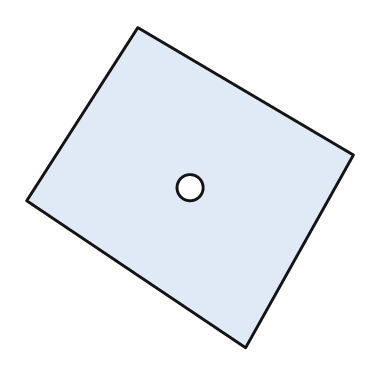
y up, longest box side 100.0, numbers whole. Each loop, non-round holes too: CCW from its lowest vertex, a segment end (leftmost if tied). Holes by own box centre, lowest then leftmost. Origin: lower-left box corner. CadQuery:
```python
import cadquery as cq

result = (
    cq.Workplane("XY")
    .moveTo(67.0, 0.0)
    .lineTo(100.0, 59.0)
    .lineTo(34.0, 98.0)
    .lineTo(0.0, 45.0)
    .close()
    .moveTo(50.0, 49.0)
    .circle(4.0)
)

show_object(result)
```